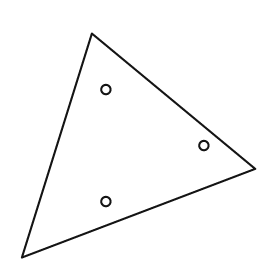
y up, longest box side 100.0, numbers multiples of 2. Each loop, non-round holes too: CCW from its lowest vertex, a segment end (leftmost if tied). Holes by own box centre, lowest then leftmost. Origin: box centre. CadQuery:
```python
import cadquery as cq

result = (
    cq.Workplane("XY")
    .moveTo(-50.0, -48.0)
    .lineTo(50.0, -10.0)
    .lineTo(-20.0, 48.0)
    .close()
    .moveTo(-14.0, -24.0)
    .circle(2.0)
    .moveTo(28.0, 0.0)
    .circle(2.0)
    .moveTo(-14.0, 24.0)
    .circle(2.0)
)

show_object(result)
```